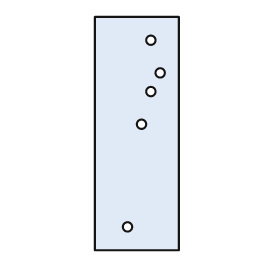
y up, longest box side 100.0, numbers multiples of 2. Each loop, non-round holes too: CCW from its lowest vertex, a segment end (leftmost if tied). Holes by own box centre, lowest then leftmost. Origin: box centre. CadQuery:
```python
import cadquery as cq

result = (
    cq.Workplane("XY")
    .moveTo(-18.0, -50.0)
    .lineTo(18.0, -50.0)
    .lineTo(18.0, 50.0)
    .lineTo(-18.0, 50.0)
    .close()
    .moveTo(-4.0, -40.0)
    .circle(2.0)
    .moveTo(2.0, 4.0)
    .circle(2.0)
    .moveTo(6.0, 18.0)
    .circle(2.0)
    .moveTo(10.0, 26.0)
    .circle(2.0)
    .moveTo(6.0, 40.0)
    .circle(2.0)
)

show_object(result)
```